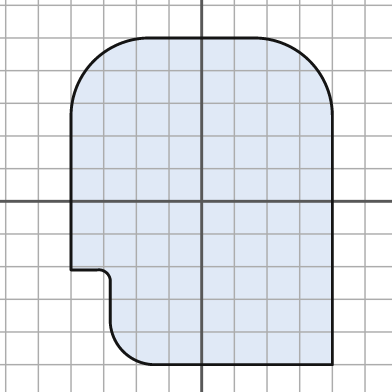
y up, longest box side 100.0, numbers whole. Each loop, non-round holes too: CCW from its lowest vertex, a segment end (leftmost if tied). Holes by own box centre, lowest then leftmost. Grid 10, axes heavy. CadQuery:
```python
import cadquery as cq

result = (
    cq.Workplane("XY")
    .moveTo(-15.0, -50.0)
    .lineTo(40.0, -50.0)
    .lineTo(40.0, 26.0)
    .threePointArc((33.0, 43.0), (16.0, 50.0))
    .lineTo(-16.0, 50.0)
    .threePointArc((-33.0, 43.0), (-40.0, 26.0))
    .lineTo(-40.0, -21.0)
    .lineTo(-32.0, -21.0)
    .threePointArc((-29.0, -22.0), (-28.0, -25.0))
    .lineTo(-28.0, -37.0)
    .threePointArc((-24.0, -46.0), (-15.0, -50.0))
    .close()
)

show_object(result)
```